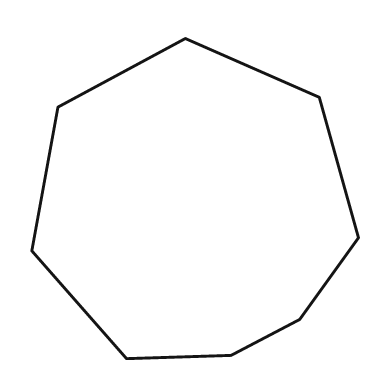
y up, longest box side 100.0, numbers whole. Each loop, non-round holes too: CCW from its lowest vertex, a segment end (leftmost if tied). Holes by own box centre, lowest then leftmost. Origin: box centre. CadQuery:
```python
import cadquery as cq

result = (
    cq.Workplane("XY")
    .moveTo(-21.0, -49.0)
    .lineTo(11.0, -48.0)
    .lineTo(32.0, -37.0)
    .lineTo(50.0, -12.0)
    .lineTo(38.0, 31.0)
    .lineTo(-3.0, 49.0)
    .lineTo(-42.0, 28.0)
    .lineTo(-50.0, -16.0)
    .close()
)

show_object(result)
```